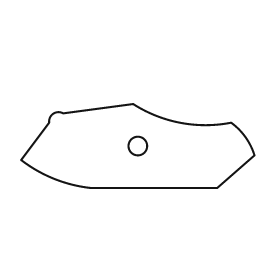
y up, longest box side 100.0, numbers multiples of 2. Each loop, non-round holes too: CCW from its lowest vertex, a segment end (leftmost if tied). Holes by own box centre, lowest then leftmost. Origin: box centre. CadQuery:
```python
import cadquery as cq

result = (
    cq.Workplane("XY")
    .moveTo(-20.0, -18.0)
    .lineTo(34.0, -18.0)
    .lineTo(50.0, -4.0)
    .threePointArc((46.0, 4.0), (40.0, 10.0))
    .threePointArc((18.0, 10.0), (-2.0, 18.0))
    .lineTo(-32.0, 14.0)
    .threePointArc((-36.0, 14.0), (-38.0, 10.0))
    .lineTo(-50.0, -6.0)
    .threePointArc((-36.0, -14.0), (-20.0, -18.0))
    .close()
    .moveTo(0.0, 0.0)
    .circle(4.0)
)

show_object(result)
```